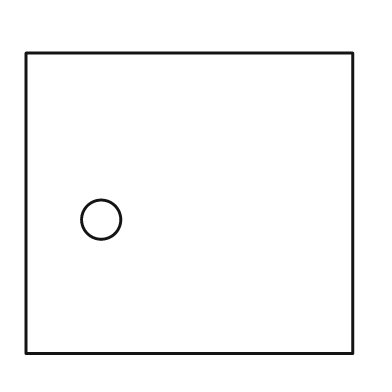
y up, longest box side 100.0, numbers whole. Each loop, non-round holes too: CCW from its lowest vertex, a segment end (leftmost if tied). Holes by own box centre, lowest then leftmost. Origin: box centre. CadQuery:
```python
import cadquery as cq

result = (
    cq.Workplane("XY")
    .moveTo(-50.0, -46.0)
    .lineTo(50.0, -46.0)
    .lineTo(50.0, 46.0)
    .lineTo(-50.0, 46.0)
    .close()
    .moveTo(-27.0, -5.0)
    .circle(6.0)
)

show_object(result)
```